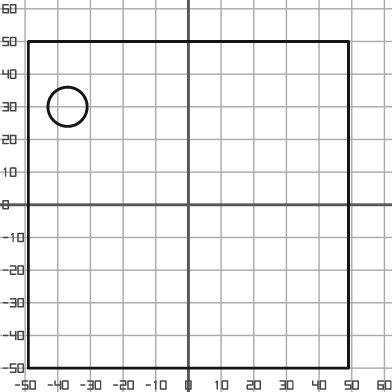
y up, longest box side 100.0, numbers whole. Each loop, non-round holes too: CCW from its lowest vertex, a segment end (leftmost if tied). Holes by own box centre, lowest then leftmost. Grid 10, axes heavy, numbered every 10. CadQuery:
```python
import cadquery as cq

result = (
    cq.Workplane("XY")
    .moveTo(-49.0, -50.0)
    .lineTo(49.0, -50.0)
    .lineTo(49.0, 50.0)
    .lineTo(-49.0, 50.0)
    .close()
    .moveTo(-37.0, 30.0)
    .circle(6.0)
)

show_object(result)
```